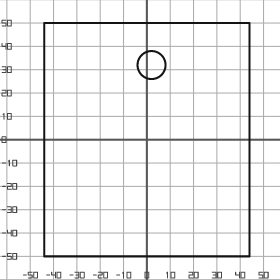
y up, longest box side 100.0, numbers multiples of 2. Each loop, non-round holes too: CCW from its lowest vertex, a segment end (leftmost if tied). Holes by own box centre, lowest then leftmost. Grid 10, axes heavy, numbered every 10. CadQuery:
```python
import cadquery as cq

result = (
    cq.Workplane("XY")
    .moveTo(-44.0, -50.0)
    .lineTo(44.0, -50.0)
    .lineTo(44.0, 50.0)
    .lineTo(-44.0, 50.0)
    .close()
    .moveTo(2.0, 32.0)
    .circle(6.0)
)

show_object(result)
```